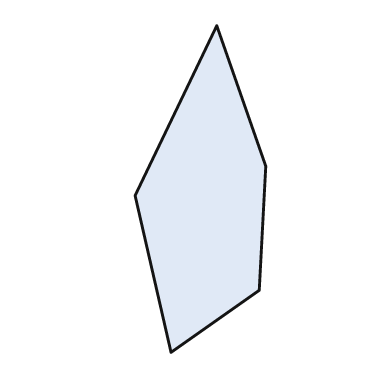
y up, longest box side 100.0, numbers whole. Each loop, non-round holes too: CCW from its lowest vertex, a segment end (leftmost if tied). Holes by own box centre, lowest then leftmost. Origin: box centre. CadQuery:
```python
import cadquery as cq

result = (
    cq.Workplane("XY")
    .moveTo(-9.0, -50.0)
    .lineTo(18.0, -31.0)
    .lineTo(20.0, 7.0)
    .lineTo(5.0, 50.0)
    .lineTo(-20.0, -2.0)
    .close()
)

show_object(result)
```